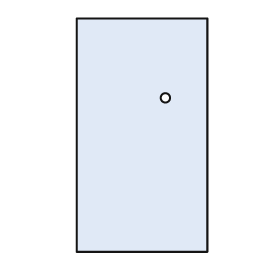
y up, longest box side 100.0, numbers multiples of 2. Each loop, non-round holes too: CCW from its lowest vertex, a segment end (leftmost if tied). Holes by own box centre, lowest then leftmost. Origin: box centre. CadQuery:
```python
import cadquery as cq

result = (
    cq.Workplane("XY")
    .moveTo(-28.0, -50.0)
    .lineTo(28.0, -50.0)
    .lineTo(28.0, 50.0)
    .lineTo(-28.0, 50.0)
    .close()
    .moveTo(10.0, 16.0)
    .circle(2.0)
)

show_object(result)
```